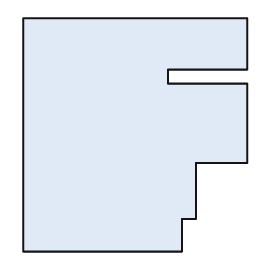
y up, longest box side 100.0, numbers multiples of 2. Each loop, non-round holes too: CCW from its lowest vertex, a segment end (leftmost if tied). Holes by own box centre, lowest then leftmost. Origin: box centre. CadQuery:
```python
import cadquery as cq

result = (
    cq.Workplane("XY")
    .moveTo(-48.0, -50.0)
    .lineTo(20.0, -50.0)
    .lineTo(20.0, -36.0)
    .lineTo(26.0, -36.0)
    .lineTo(26.0, -12.0)
    .lineTo(48.0, -12.0)
    .lineTo(48.0, 22.0)
    .lineTo(14.0, 22.0)
    .lineTo(14.0, 28.0)
    .lineTo(48.0, 28.0)
    .lineTo(48.0, 50.0)
    .lineTo(-48.0, 50.0)
    .close()
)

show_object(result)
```